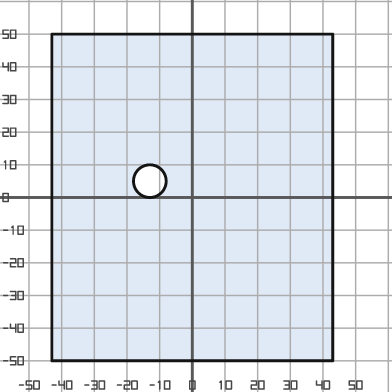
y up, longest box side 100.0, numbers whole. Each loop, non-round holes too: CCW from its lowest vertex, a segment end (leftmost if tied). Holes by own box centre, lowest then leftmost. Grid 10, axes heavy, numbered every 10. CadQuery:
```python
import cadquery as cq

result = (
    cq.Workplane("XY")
    .moveTo(-43.0, -50.0)
    .lineTo(43.0, -50.0)
    .lineTo(43.0, 50.0)
    .lineTo(-43.0, 50.0)
    .close()
    .moveTo(-13.0, 5.0)
    .circle(5.0)
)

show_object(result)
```